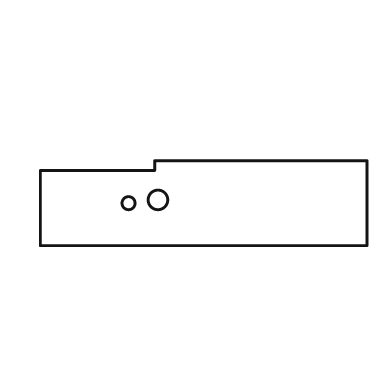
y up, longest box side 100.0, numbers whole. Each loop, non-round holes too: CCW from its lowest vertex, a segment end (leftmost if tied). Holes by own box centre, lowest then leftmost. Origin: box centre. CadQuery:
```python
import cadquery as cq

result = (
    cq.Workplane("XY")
    .moveTo(-50.0, -13.0)
    .lineTo(50.0, -13.0)
    .lineTo(50.0, 13.0)
    .lineTo(-15.0, 13.0)
    .lineTo(-15.0, 10.0)
    .lineTo(-50.0, 10.0)
    .close()
    .moveTo(-23.0, 0.0)
    .circle(2.0)
    .moveTo(-14.0, 1.0)
    .circle(3.0)
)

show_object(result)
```